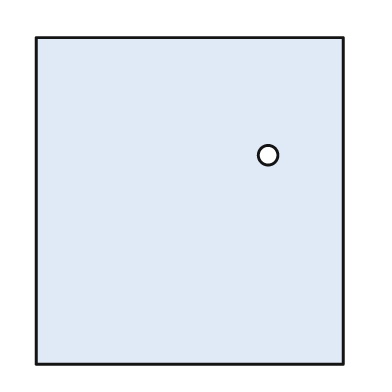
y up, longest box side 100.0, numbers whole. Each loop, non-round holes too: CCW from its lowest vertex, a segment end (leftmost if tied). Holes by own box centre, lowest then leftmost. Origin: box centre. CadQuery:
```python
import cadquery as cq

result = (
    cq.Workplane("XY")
    .moveTo(-47.0, -50.0)
    .lineTo(47.0, -50.0)
    .lineTo(47.0, 50.0)
    .lineTo(-47.0, 50.0)
    .close()
    .moveTo(24.0, 14.0)
    .circle(3.0)
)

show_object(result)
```